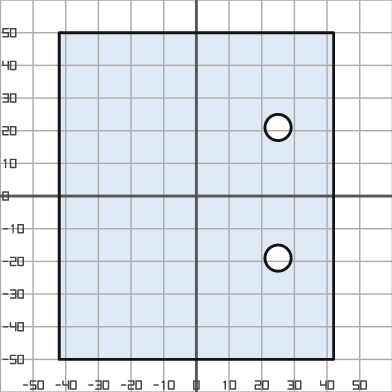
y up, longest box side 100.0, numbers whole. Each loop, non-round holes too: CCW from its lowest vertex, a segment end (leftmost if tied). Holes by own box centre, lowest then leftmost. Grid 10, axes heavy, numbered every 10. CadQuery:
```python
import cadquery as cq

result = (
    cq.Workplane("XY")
    .moveTo(-42.0, -50.0)
    .lineTo(42.0, -50.0)
    .lineTo(42.0, 50.0)
    .lineTo(-42.0, 50.0)
    .close()
    .moveTo(25.0, -19.0)
    .circle(4.0)
    .moveTo(25.0, 21.0)
    .circle(4.0)
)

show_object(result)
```